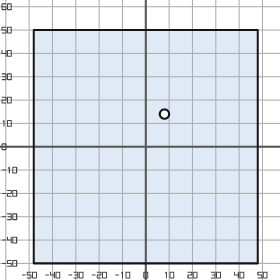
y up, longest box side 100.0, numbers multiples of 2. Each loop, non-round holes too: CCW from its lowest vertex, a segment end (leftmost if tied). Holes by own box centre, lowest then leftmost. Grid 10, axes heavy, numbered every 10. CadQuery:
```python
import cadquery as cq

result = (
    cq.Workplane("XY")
    .moveTo(-48.0, -50.0)
    .lineTo(48.0, -50.0)
    .lineTo(48.0, 50.0)
    .lineTo(-48.0, 50.0)
    .close()
    .moveTo(8.0, 14.0)
    .circle(2.0)
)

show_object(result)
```